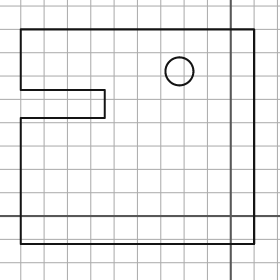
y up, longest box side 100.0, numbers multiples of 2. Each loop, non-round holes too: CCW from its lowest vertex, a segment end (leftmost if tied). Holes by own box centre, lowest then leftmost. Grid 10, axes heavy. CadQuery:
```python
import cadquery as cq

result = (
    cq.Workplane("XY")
    .moveTo(-90.0, -12.0)
    .lineTo(10.0, -12.0)
    .lineTo(10.0, 80.0)
    .lineTo(-90.0, 80.0)
    .lineTo(-90.0, 54.0)
    .lineTo(-54.0, 54.0)
    .lineTo(-54.0, 42.0)
    .lineTo(-90.0, 42.0)
    .close()
    .moveTo(-22.0, 62.0)
    .circle(6.0)
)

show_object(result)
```